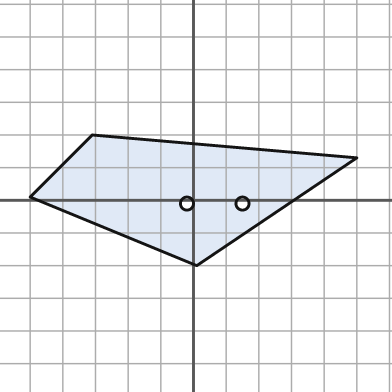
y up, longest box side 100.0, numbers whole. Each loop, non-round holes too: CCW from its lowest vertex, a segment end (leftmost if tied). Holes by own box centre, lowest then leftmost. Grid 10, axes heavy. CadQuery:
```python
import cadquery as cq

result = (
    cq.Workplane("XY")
    .moveTo(1.0, -20.0)
    .lineTo(50.0, 13.0)
    .lineTo(-31.0, 20.0)
    .lineTo(-50.0, 1.0)
    .close()
    .moveTo(-2.0, -1.0)
    .circle(2.0)
    .moveTo(15.0, -1.0)
    .circle(2.0)
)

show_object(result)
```